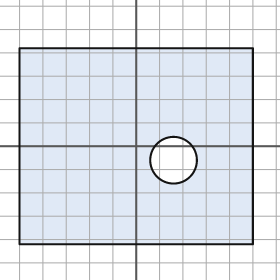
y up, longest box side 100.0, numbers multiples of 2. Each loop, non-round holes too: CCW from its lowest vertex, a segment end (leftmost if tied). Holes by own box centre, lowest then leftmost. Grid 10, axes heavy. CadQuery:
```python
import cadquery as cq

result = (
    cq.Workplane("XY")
    .moveTo(-50.0, -42.0)
    .lineTo(50.0, -42.0)
    .lineTo(50.0, 42.0)
    .lineTo(-50.0, 42.0)
    .close()
    .moveTo(16.0, -6.0)
    .circle(10.0)
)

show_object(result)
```